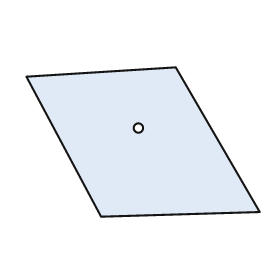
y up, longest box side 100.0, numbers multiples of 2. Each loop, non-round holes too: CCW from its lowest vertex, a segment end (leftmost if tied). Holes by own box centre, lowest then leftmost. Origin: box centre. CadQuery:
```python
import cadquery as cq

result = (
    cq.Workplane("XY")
    .moveTo(-18.0, -32.0)
    .lineTo(50.0, -30.0)
    .lineTo(14.0, 32.0)
    .lineTo(-50.0, 28.0)
    .close()
    .moveTo(-2.0, 6.0)
    .circle(2.0)
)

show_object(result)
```